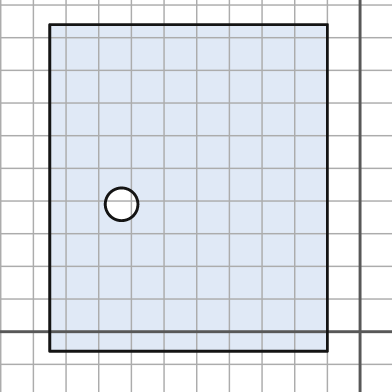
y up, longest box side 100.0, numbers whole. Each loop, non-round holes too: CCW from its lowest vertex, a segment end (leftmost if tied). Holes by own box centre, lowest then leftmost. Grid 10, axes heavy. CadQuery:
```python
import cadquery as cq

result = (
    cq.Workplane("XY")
    .moveTo(-95.0, -6.0)
    .lineTo(-10.0, -6.0)
    .lineTo(-10.0, 94.0)
    .lineTo(-95.0, 94.0)
    .close()
    .moveTo(-73.0, 39.0)
    .circle(5.0)
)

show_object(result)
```